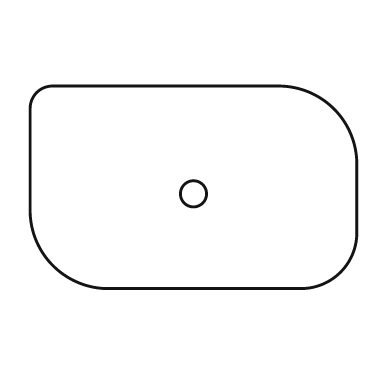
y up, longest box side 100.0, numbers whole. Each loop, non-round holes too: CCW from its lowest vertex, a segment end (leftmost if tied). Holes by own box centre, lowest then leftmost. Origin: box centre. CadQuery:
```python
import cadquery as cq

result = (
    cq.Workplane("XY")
    .moveTo(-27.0, -31.0)
    .lineTo(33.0, -31.0)
    .threePointArc((45.0, -26.0), (50.0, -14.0))
    .lineTo(50.0, 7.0)
    .threePointArc((43.0, 24.0), (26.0, 31.0))
    .lineTo(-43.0, 31.0)
    .threePointArc((-48.0, 29.0), (-50.0, 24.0))
    .lineTo(-50.0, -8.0)
    .threePointArc((-43.0, -24.0), (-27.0, -31.0))
    .close()
    .moveTo(0.0, -2.0)
    .circle(4.0)
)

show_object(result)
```